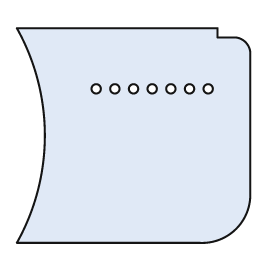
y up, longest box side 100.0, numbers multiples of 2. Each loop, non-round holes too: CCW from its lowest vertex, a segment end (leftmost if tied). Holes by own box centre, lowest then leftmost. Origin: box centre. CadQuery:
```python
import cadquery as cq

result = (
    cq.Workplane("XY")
    .moveTo(-50.0, -46.0)
    .lineTo(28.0, -46.0)
    .threePointArc((44.0, -40.0), (50.0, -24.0))
    .lineTo(50.0, 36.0)
    .threePointArc((48.0, 40.0), (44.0, 42.0))
    .lineTo(36.0, 42.0)
    .lineTo(36.0, 46.0)
    .lineTo(-50.0, 46.0)
    .threePointArc((-38.0, 0.0), (-50.0, -46.0))
    .close()
    .moveTo(-16.0, 20.0)
    .circle(2.0)
    .moveTo(-8.0, 20.0)
    .circle(2.0)
    .moveTo(0.0, 20.0)
    .circle(2.0)
    .moveTo(8.0, 20.0)
    .circle(2.0)
    .moveTo(16.0, 20.0)
    .circle(2.0)
    .moveTo(24.0, 20.0)
    .circle(2.0)
    .moveTo(32.0, 20.0)
    .circle(2.0)
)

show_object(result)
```